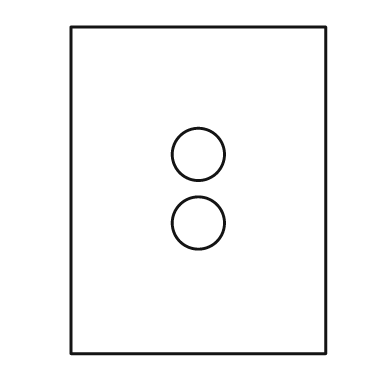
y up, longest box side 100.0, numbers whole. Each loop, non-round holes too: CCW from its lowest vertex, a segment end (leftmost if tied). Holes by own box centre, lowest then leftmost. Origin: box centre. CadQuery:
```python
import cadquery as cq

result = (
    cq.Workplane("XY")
    .moveTo(-39.0, -50.0)
    .lineTo(39.0, -50.0)
    .lineTo(39.0, 50.0)
    .lineTo(-39.0, 50.0)
    .close()
    .moveTo(0.0, -10.0)
    .circle(8.0)
    .moveTo(0.0, 11.0)
    .circle(8.0)
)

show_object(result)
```